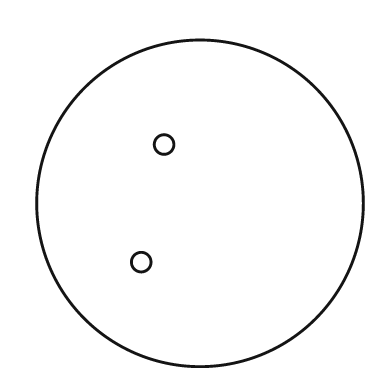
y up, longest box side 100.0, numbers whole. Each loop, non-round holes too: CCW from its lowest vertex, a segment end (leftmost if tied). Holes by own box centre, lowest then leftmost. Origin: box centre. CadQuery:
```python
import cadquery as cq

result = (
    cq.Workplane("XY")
    .moveTo(0.0, 0.0)
    .circle(50.0)
    .moveTo(-18.0, -18.0)
    .circle(3.0)
    .moveTo(-11.0, 18.0)
    .circle(3.0)
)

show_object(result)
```